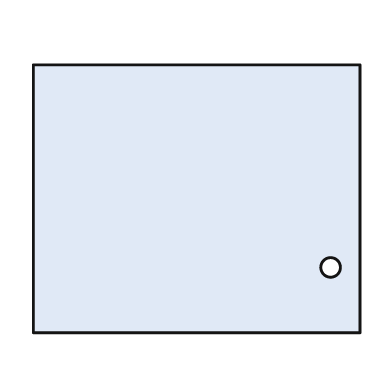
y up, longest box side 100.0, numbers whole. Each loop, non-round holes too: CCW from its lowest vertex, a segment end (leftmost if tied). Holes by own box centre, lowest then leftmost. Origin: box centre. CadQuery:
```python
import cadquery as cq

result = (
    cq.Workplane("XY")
    .moveTo(-50.0, -41.0)
    .lineTo(50.0, -41.0)
    .lineTo(50.0, 41.0)
    .lineTo(-50.0, 41.0)
    .close()
    .moveTo(41.0, -21.0)
    .circle(3.0)
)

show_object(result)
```